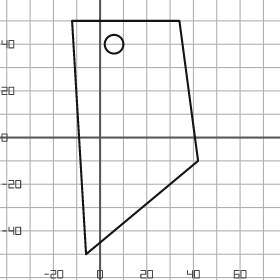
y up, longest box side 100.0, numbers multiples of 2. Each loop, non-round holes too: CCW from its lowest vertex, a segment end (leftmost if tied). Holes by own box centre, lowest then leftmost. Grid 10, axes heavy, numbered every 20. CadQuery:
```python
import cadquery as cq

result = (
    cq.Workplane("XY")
    .moveTo(-6.0, -50.0)
    .lineTo(42.0, -10.0)
    .lineTo(34.0, 50.0)
    .lineTo(-12.0, 50.0)
    .close()
    .moveTo(6.0, 40.0)
    .circle(4.0)
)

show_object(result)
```